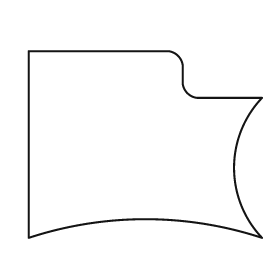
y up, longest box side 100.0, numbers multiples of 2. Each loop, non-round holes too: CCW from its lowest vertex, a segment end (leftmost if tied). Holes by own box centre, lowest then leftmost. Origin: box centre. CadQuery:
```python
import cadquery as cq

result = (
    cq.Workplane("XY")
    .moveTo(-50.0, -40.0)
    .threePointArc((0.0, -32.0), (50.0, -40.0))
    .threePointArc((38.0, -10.0), (50.0, 20.0))
    .lineTo(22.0, 20.0)
    .threePointArc((18.0, 22.0), (16.0, 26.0))
    .lineTo(16.0, 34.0)
    .threePointArc((14.0, 38.0), (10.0, 40.0))
    .lineTo(-50.0, 40.0)
    .close()
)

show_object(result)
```